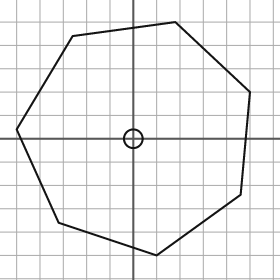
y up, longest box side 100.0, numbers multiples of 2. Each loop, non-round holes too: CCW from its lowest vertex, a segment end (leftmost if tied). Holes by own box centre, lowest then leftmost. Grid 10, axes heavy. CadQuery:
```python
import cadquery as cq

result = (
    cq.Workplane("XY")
    .moveTo(10.0, -50.0)
    .lineTo(46.0, -24.0)
    .lineTo(50.0, 20.0)
    .lineTo(18.0, 50.0)
    .lineTo(-26.0, 44.0)
    .lineTo(-50.0, 4.0)
    .lineTo(-32.0, -36.0)
    .close()
    .moveTo(0.0, 0.0)
    .circle(4.0)
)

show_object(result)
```